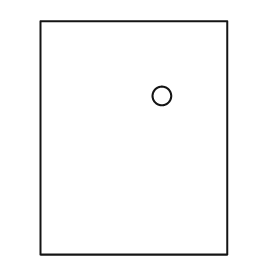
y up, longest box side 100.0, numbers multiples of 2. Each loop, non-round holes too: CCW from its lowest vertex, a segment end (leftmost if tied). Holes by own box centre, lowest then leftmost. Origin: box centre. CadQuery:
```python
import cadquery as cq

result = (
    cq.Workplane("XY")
    .moveTo(-40.0, -50.0)
    .lineTo(40.0, -50.0)
    .lineTo(40.0, 50.0)
    .lineTo(-40.0, 50.0)
    .close()
    .moveTo(12.0, 18.0)
    .circle(4.0)
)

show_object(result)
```